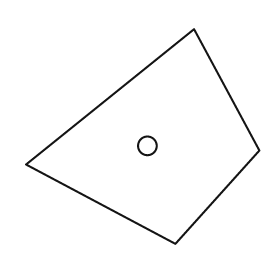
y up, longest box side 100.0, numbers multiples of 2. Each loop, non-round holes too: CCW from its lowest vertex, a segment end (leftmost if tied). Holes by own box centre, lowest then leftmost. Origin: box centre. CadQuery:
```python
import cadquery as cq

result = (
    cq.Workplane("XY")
    .moveTo(14.0, -46.0)
    .lineTo(50.0, -6.0)
    .lineTo(22.0, 46.0)
    .lineTo(-50.0, -12.0)
    .close()
    .moveTo(2.0, -4.0)
    .circle(4.0)
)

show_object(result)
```